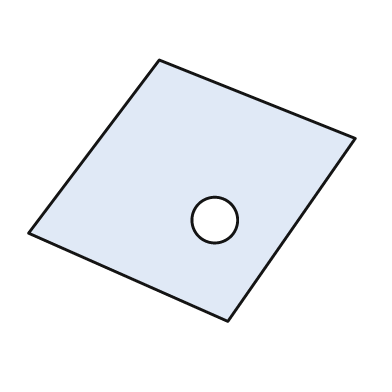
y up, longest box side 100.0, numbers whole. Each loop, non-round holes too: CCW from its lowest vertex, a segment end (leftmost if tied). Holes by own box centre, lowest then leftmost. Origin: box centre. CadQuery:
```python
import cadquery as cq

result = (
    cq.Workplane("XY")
    .moveTo(11.0, -40.0)
    .lineTo(50.0, 16.0)
    .lineTo(-10.0, 40.0)
    .lineTo(-50.0, -13.0)
    .close()
    .moveTo(7.0, -9.0)
    .circle(7.0)
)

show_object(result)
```